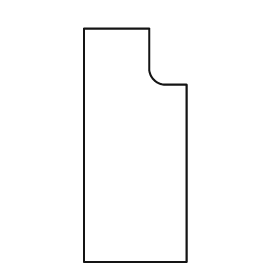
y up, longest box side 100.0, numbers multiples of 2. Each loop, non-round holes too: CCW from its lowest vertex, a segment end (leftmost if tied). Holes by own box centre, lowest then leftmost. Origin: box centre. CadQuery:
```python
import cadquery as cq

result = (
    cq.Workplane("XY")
    .moveTo(-22.0, -50.0)
    .lineTo(22.0, -50.0)
    .lineTo(22.0, 26.0)
    .lineTo(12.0, 26.0)
    .threePointArc((8.0, 28.0), (6.0, 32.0))
    .lineTo(6.0, 50.0)
    .lineTo(-22.0, 50.0)
    .close()
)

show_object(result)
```